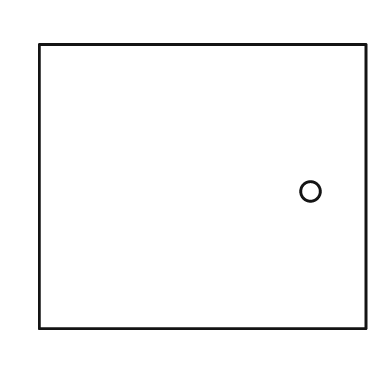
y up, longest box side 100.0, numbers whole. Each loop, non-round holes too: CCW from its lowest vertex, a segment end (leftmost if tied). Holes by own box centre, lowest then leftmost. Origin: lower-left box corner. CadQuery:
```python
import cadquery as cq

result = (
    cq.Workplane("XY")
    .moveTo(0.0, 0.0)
    .lineTo(100.0, 0.0)
    .lineTo(100.0, 87.0)
    .lineTo(0.0, 87.0)
    .close()
    .moveTo(83.0, 42.0)
    .circle(3.0)
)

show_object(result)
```